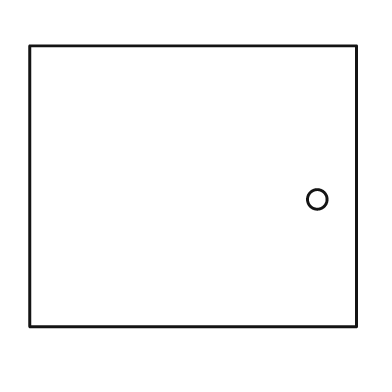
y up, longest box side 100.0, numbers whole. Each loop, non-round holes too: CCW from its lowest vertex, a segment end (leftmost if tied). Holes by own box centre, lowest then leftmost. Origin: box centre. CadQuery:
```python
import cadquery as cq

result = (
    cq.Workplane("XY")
    .moveTo(-50.0, -43.0)
    .lineTo(50.0, -43.0)
    .lineTo(50.0, 43.0)
    .lineTo(-50.0, 43.0)
    .close()
    .moveTo(38.0, -4.0)
    .circle(3.0)
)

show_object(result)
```